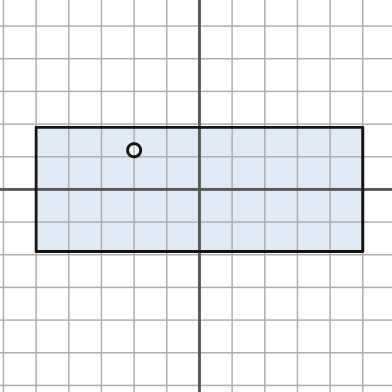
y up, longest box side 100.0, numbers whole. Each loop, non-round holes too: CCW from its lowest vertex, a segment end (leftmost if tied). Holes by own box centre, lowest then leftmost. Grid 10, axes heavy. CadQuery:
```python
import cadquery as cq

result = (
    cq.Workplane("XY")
    .moveTo(-50.0, -19.0)
    .lineTo(50.0, -19.0)
    .lineTo(50.0, 19.0)
    .lineTo(-50.0, 19.0)
    .close()
    .moveTo(-20.0, 12.0)
    .circle(2.0)
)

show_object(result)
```